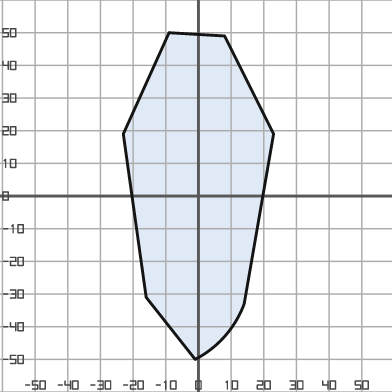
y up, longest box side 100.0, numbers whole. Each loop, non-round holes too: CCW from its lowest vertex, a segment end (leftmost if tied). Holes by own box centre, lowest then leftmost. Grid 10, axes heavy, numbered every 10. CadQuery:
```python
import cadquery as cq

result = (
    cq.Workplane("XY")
    .moveTo(-1.0, -50.0)
    .threePointArc((8.0, -43.0), (14.0, -33.0))
    .lineTo(23.0, 19.0)
    .lineTo(8.0, 49.0)
    .lineTo(-9.0, 50.0)
    .lineTo(-23.0, 19.0)
    .lineTo(-16.0, -31.0)
    .close()
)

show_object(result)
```